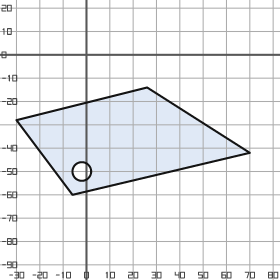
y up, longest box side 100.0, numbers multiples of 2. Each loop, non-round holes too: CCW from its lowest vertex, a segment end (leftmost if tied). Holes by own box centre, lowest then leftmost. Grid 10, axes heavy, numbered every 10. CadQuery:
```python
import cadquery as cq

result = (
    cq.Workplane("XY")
    .moveTo(-6.0, -60.0)
    .lineTo(70.0, -42.0)
    .lineTo(26.0, -14.0)
    .lineTo(-30.0, -28.0)
    .close()
    .moveTo(-2.0, -50.0)
    .circle(4.0)
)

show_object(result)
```